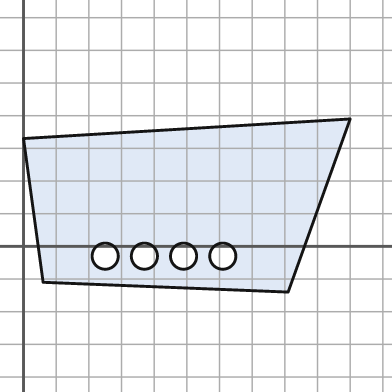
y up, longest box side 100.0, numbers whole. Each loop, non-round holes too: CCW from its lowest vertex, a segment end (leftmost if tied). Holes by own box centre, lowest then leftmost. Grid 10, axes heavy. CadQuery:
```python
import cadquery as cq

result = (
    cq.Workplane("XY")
    .moveTo(81.0, -14.0)
    .lineTo(100.0, 39.0)
    .lineTo(0.0, 33.0)
    .lineTo(6.0, -11.0)
    .close()
    .moveTo(25.0, -3.0)
    .circle(4.0)
    .moveTo(37.0, -3.0)
    .circle(4.0)
    .moveTo(49.0, -3.0)
    .circle(4.0)
    .moveTo(61.0, -3.0)
    .circle(4.0)
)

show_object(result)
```